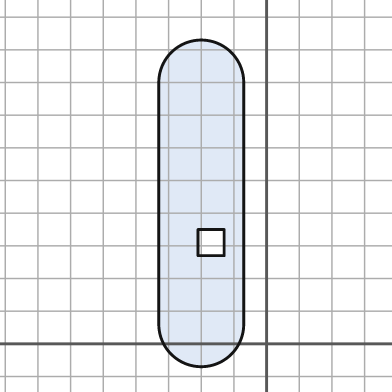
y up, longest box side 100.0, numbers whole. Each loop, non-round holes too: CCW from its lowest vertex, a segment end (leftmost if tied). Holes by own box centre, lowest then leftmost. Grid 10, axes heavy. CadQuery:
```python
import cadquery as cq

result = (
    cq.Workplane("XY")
    .moveTo(-33.0, 6.0)
    .threePointArc((-20.0, -7.0), (-7.0, 6.0))
    .lineTo(-7.0, 80.0)
    .threePointArc((-20.0, 93.0), (-33.0, 80.0))
    .close()
    .moveTo(-21.0, 27.0)
    .lineTo(-13.0, 27.0)
    .lineTo(-13.0, 35.0)
    .lineTo(-21.0, 35.0)
    .close()
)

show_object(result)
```